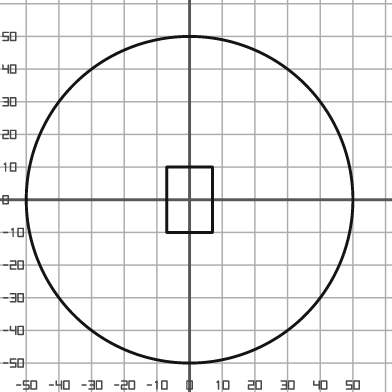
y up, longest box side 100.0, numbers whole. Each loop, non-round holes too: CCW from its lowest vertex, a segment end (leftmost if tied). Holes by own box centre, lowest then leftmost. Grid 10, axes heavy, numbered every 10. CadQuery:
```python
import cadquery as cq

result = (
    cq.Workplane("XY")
    .moveTo(0.0, 0.0)
    .circle(50.0)
    .moveTo(-7.0, -10.0)
    .lineTo(7.0, -10.0)
    .lineTo(7.0, 10.0)
    .lineTo(-7.0, 10.0)
    .close()
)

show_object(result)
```